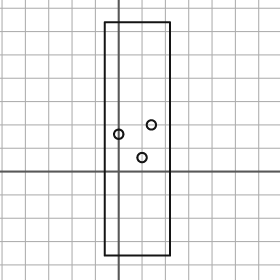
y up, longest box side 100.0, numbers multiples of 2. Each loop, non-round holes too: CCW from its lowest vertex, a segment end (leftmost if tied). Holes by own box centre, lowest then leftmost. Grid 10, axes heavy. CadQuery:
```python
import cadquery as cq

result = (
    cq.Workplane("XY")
    .moveTo(-6.0, -36.0)
    .lineTo(22.0, -36.0)
    .lineTo(22.0, 64.0)
    .lineTo(-6.0, 64.0)
    .close()
    .moveTo(10.0, 6.0)
    .circle(2.0)
    .moveTo(0.0, 16.0)
    .circle(2.0)
    .moveTo(14.0, 20.0)
    .circle(2.0)
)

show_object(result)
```